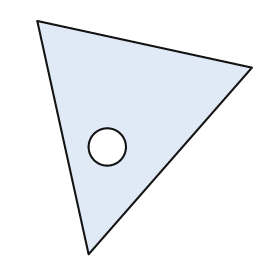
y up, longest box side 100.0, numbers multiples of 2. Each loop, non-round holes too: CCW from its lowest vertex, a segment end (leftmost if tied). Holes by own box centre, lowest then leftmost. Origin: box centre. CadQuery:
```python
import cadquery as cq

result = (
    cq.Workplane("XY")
    .moveTo(-24.0, -50.0)
    .lineTo(46.0, 30.0)
    .lineTo(-46.0, 50.0)
    .close()
    .moveTo(-16.0, -4.0)
    .circle(8.0)
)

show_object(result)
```